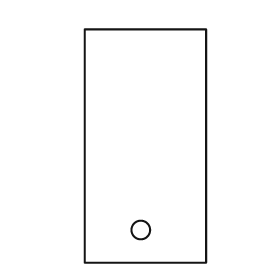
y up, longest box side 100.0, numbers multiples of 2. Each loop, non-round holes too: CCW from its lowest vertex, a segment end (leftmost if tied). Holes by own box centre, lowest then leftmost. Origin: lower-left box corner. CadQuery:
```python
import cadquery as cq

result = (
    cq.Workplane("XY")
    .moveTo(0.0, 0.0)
    .lineTo(52.0, 0.0)
    .lineTo(52.0, 100.0)
    .lineTo(0.0, 100.0)
    .close()
    .moveTo(24.0, 14.0)
    .circle(4.0)
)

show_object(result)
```